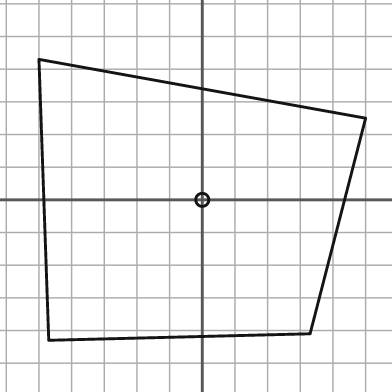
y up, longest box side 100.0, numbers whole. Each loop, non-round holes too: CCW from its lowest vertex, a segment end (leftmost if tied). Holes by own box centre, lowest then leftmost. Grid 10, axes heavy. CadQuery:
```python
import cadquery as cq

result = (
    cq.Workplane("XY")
    .moveTo(-47.0, -43.0)
    .lineTo(33.0, -41.0)
    .lineTo(50.0, 25.0)
    .lineTo(-50.0, 43.0)
    .close()
    .moveTo(0.0, 0.0)
    .circle(2.0)
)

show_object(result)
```